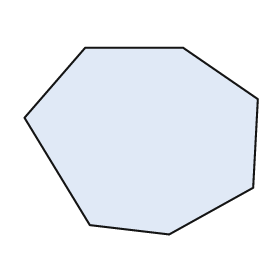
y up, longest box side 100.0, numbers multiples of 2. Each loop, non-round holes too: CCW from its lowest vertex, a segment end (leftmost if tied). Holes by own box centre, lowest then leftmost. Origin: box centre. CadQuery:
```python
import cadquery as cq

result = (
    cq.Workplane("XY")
    .moveTo(12.0, -40.0)
    .lineTo(48.0, -20.0)
    .lineTo(50.0, 18.0)
    .lineTo(18.0, 40.0)
    .lineTo(-24.0, 40.0)
    .lineTo(-50.0, 10.0)
    .lineTo(-22.0, -36.0)
    .close()
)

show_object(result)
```